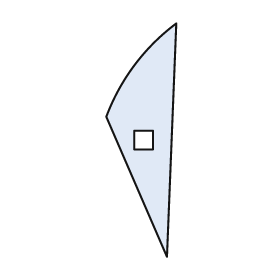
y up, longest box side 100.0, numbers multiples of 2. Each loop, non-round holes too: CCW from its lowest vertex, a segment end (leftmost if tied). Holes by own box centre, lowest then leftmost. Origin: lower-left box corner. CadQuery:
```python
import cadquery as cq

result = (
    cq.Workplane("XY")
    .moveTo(26.0, 0.0)
    .lineTo(30.0, 100.0)
    .threePointArc((12.0, 82.0), (0.0, 60.0))
    .close()
    .moveTo(12.0, 46.0)
    .lineTo(20.0, 46.0)
    .lineTo(20.0, 54.0)
    .lineTo(12.0, 54.0)
    .close()
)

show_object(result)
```